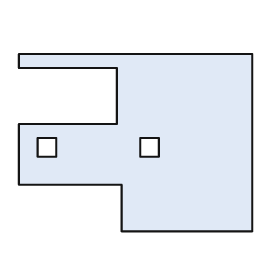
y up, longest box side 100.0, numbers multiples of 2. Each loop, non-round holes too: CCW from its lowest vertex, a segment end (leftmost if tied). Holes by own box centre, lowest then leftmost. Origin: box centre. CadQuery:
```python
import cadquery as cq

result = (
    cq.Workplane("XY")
    .moveTo(-6.0, -38.0)
    .lineTo(50.0, -38.0)
    .lineTo(50.0, 38.0)
    .lineTo(-50.0, 38.0)
    .lineTo(-50.0, 32.0)
    .lineTo(-8.0, 32.0)
    .lineTo(-8.0, 8.0)
    .lineTo(-50.0, 8.0)
    .lineTo(-50.0, -18.0)
    .lineTo(-6.0, -18.0)
    .close()
    .moveTo(-42.0, -6.0)
    .lineTo(-34.0, -6.0)
    .lineTo(-34.0, 2.0)
    .lineTo(-42.0, 2.0)
    .close()
    .moveTo(2.0, -6.0)
    .lineTo(10.0, -6.0)
    .lineTo(10.0, 2.0)
    .lineTo(2.0, 2.0)
    .close()
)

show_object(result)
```